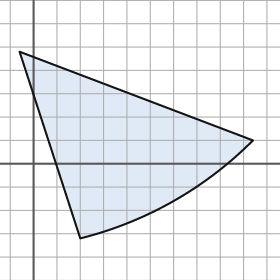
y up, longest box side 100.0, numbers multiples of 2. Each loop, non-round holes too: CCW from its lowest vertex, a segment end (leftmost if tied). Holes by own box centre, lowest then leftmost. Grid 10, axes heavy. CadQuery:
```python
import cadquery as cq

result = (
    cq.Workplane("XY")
    .moveTo(20.0, -32.0)
    .threePointArc((60.0, -16.0), (94.0, 10.0))
    .lineTo(-6.0, 48.0)
    .close()
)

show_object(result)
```